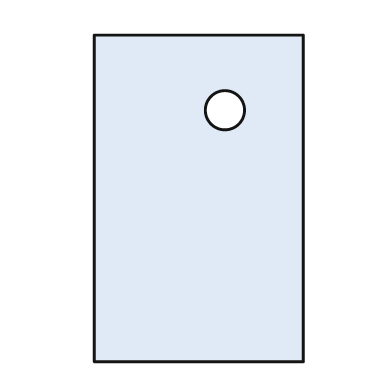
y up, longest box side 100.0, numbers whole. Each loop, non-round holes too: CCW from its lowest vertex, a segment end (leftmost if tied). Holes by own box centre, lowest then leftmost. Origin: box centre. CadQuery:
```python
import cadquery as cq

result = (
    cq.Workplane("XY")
    .moveTo(-32.0, -50.0)
    .lineTo(32.0, -50.0)
    .lineTo(32.0, 50.0)
    .lineTo(-32.0, 50.0)
    .close()
    .moveTo(8.0, 27.0)
    .circle(6.0)
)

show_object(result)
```